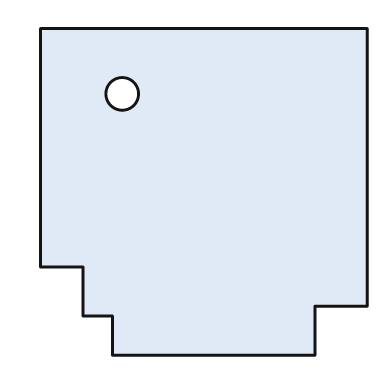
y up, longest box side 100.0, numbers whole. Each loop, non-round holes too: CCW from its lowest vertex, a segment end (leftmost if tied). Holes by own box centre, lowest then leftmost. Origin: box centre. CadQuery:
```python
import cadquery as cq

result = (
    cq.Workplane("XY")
    .moveTo(-28.0, -50.0)
    .lineTo(34.0, -50.0)
    .lineTo(34.0, -35.0)
    .lineTo(50.0, -35.0)
    .lineTo(50.0, 50.0)
    .lineTo(-50.0, 50.0)
    .lineTo(-50.0, -23.0)
    .lineTo(-37.0, -23.0)
    .lineTo(-37.0, -38.0)
    .lineTo(-28.0, -38.0)
    .close()
    .moveTo(-25.0, 30.0)
    .circle(5.0)
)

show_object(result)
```